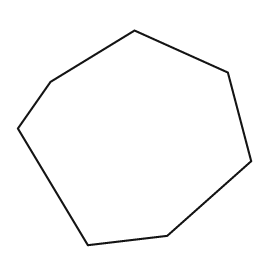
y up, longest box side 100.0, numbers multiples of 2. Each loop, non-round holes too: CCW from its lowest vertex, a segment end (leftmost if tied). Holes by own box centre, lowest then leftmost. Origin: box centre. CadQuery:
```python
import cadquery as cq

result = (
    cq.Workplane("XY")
    .moveTo(-20.0, -46.0)
    .lineTo(14.0, -42.0)
    .lineTo(50.0, -10.0)
    .lineTo(40.0, 28.0)
    .lineTo(0.0, 46.0)
    .lineTo(-36.0, 24.0)
    .lineTo(-50.0, 4.0)
    .close()
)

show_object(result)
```